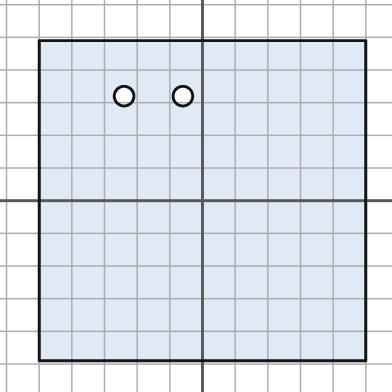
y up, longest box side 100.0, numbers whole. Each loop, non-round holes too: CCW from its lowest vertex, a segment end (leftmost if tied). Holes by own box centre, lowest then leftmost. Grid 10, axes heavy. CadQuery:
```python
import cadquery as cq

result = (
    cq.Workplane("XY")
    .moveTo(-50.0, -49.0)
    .lineTo(50.0, -49.0)
    .lineTo(50.0, 49.0)
    .lineTo(-50.0, 49.0)
    .close()
    .moveTo(-24.0, 32.0)
    .circle(3.0)
    .moveTo(-6.0, 32.0)
    .circle(3.0)
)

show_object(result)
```